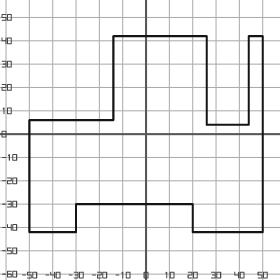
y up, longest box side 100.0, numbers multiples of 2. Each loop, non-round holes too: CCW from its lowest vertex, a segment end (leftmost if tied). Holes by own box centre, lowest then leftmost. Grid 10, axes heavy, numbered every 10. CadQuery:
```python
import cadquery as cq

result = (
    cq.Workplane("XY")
    .moveTo(-50.0, -42.0)
    .lineTo(-30.0, -42.0)
    .lineTo(-30.0, -30.0)
    .lineTo(20.0, -30.0)
    .lineTo(20.0, -42.0)
    .lineTo(50.0, -42.0)
    .lineTo(50.0, 42.0)
    .lineTo(44.0, 42.0)
    .lineTo(44.0, 4.0)
    .lineTo(26.0, 4.0)
    .lineTo(26.0, 42.0)
    .lineTo(-14.0, 42.0)
    .lineTo(-14.0, 6.0)
    .lineTo(-50.0, 6.0)
    .close()
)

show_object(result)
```